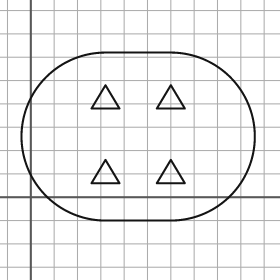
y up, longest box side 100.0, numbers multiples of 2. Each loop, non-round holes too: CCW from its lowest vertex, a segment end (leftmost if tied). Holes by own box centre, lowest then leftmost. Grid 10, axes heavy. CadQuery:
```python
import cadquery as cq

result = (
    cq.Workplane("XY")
    .moveTo(32.0, -10.0)
    .lineTo(60.0, -10.0)
    .threePointArc((96.0, 26.0), (60.0, 62.0))
    .lineTo(32.0, 62.0)
    .threePointArc((-4.0, 26.0), (32.0, -10.0))
    .close()
    .moveTo(26.0, 6.0)
    .lineTo(38.0, 6.0)
    .lineTo(32.0, 16.0)
    .close()
    .moveTo(54.0, 6.0)
    .lineTo(66.0, 6.0)
    .lineTo(60.0, 16.0)
    .close()
    .moveTo(26.0, 38.0)
    .lineTo(38.0, 38.0)
    .lineTo(32.0, 48.0)
    .close()
    .moveTo(54.0, 38.0)
    .lineTo(66.0, 38.0)
    .lineTo(60.0, 48.0)
    .close()
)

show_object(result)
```